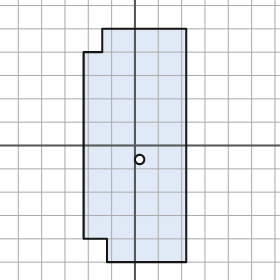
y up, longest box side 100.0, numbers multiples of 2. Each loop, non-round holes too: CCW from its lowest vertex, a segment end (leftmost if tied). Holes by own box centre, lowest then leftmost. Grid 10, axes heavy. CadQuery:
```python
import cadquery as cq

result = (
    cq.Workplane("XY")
    .moveTo(-12.0, -50.0)
    .lineTo(22.0, -50.0)
    .lineTo(22.0, 50.0)
    .lineTo(-14.0, 50.0)
    .lineTo(-14.0, 40.0)
    .lineTo(-22.0, 40.0)
    .lineTo(-22.0, -40.0)
    .lineTo(-12.0, -40.0)
    .close()
    .moveTo(2.0, -6.0)
    .circle(2.0)
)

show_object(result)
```